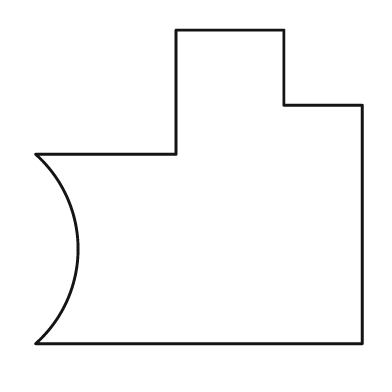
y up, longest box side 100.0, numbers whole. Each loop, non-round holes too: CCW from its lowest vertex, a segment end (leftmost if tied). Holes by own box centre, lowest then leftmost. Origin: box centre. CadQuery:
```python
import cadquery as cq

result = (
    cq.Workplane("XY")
    .moveTo(-50.0, -48.0)
    .lineTo(50.0, -48.0)
    .lineTo(50.0, 25.0)
    .lineTo(26.0, 25.0)
    .lineTo(26.0, 48.0)
    .lineTo(-7.0, 48.0)
    .lineTo(-7.0, 10.0)
    .lineTo(-50.0, 10.0)
    .threePointArc((-37.0, -19.0), (-50.0, -48.0))
    .close()
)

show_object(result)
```